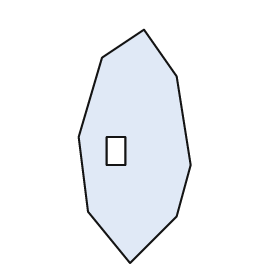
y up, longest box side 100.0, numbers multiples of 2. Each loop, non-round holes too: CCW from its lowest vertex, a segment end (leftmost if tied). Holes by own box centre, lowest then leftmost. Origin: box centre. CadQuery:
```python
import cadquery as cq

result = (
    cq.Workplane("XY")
    .moveTo(-2.0, -50.0)
    .lineTo(18.0, -30.0)
    .lineTo(24.0, -8.0)
    .lineTo(18.0, 30.0)
    .lineTo(4.0, 50.0)
    .lineTo(-14.0, 38.0)
    .lineTo(-24.0, 4.0)
    .lineTo(-20.0, -28.0)
    .close()
    .moveTo(-12.0, -8.0)
    .lineTo(-4.0, -8.0)
    .lineTo(-4.0, 4.0)
    .lineTo(-12.0, 4.0)
    .close()
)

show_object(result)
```